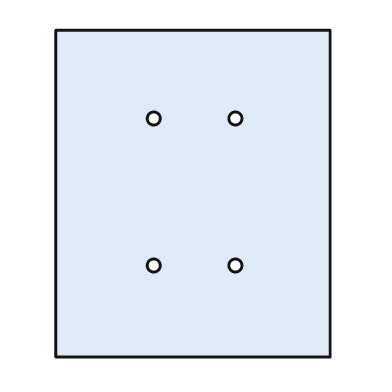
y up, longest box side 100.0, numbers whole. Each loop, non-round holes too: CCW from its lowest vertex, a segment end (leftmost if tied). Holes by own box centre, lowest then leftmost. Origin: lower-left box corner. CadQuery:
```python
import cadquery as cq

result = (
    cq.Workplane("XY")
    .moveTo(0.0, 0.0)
    .lineTo(84.0, 0.0)
    .lineTo(84.0, 100.0)
    .lineTo(0.0, 100.0)
    .close()
    .moveTo(30.0, 28.0)
    .circle(2.0)
    .moveTo(55.0, 28.0)
    .circle(2.0)
    .moveTo(30.0, 73.0)
    .circle(2.0)
    .moveTo(55.0, 73.0)
    .circle(2.0)
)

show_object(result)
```